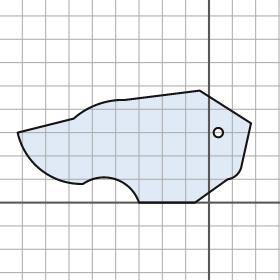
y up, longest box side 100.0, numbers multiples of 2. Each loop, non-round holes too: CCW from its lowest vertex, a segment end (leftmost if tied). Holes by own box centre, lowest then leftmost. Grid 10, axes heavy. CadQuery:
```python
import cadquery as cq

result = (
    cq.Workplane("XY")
    .moveTo(-30.0, 0.0)
    .lineTo(-6.0, 0.0)
    .lineTo(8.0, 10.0)
    .threePointArc((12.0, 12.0), (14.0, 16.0))
    .lineTo(18.0, 34.0)
    .lineTo(-4.0, 48.0)
    .lineTo(-36.0, 44.0)
    .threePointArc((-48.0, 42.0), (-58.0, 36.0))
    .lineTo(-82.0, 30.0)
    .threePointArc((-72.0, 14.0), (-54.0, 8.0))
    .threePointArc((-40.0, 10.0), (-30.0, 0.0))
    .close()
    .moveTo(4.0, 30.0)
    .circle(2.0)
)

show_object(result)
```